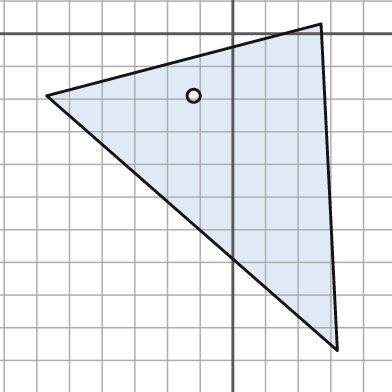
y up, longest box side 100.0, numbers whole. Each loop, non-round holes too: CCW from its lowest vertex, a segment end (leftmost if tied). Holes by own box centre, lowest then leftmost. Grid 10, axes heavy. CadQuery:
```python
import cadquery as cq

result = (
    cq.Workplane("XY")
    .moveTo(32.0, -97.0)
    .lineTo(27.0, 3.0)
    .lineTo(-57.0, -19.0)
    .close()
    .moveTo(-12.0, -19.0)
    .circle(2.0)
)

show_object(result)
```